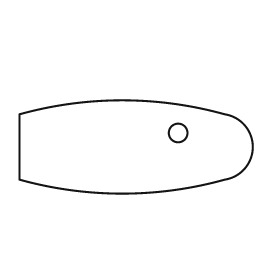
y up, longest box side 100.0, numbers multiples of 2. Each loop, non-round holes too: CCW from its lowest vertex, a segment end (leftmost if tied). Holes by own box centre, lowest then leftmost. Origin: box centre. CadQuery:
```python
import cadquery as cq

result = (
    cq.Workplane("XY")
    .moveTo(-50.0, -14.0)
    .threePointArc((-6.0, -20.0), (38.0, -14.0))
    .threePointArc((50.0, 0.0), (38.0, 14.0))
    .threePointArc((-6.0, 20.0), (-50.0, 14.0))
    .close()
    .moveTo(18.0, 6.0)
    .circle(4.0)
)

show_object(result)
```